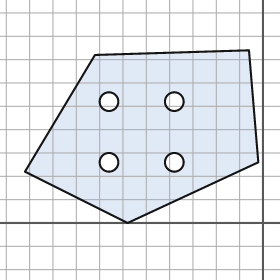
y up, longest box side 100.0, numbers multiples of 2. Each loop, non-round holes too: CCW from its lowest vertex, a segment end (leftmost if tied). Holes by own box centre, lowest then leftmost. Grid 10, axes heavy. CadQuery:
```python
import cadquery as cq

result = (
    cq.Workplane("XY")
    .moveTo(-58.0, 0.0)
    .lineTo(-2.0, 26.0)
    .lineTo(-6.0, 74.0)
    .lineTo(-72.0, 72.0)
    .lineTo(-102.0, 22.0)
    .close()
    .moveTo(-66.0, 26.0)
    .circle(4.0)
    .moveTo(-38.0, 26.0)
    .circle(4.0)
    .moveTo(-66.0, 52.0)
    .circle(4.0)
    .moveTo(-38.0, 52.0)
    .circle(4.0)
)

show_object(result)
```